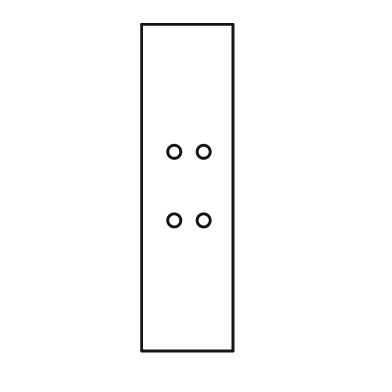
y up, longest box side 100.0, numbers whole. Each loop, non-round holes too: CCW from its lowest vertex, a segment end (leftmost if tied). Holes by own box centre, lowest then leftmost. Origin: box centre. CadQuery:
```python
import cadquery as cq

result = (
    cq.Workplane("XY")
    .moveTo(-14.0, -50.0)
    .lineTo(14.0, -50.0)
    .lineTo(14.0, 50.0)
    .lineTo(-14.0, 50.0)
    .close()
    .moveTo(-4.0, -10.0)
    .circle(2.0)
    .moveTo(5.0, -10.0)
    .circle(2.0)
    .moveTo(-4.0, 11.0)
    .circle(2.0)
    .moveTo(5.0, 11.0)
    .circle(2.0)
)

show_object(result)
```